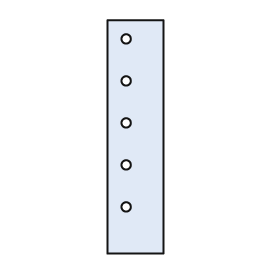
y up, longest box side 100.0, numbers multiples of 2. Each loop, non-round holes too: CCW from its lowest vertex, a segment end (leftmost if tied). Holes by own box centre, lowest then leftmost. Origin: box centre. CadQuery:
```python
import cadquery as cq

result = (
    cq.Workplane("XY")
    .moveTo(-12.0, -50.0)
    .lineTo(12.0, -50.0)
    .lineTo(12.0, 50.0)
    .lineTo(-12.0, 50.0)
    .close()
    .moveTo(-4.0, -30.0)
    .circle(2.0)
    .moveTo(-4.0, -12.0)
    .circle(2.0)
    .moveTo(-4.0, 6.0)
    .circle(2.0)
    .moveTo(-4.0, 24.0)
    .circle(2.0)
    .moveTo(-4.0, 42.0)
    .circle(2.0)
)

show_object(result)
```